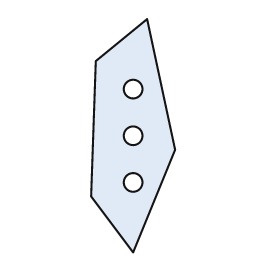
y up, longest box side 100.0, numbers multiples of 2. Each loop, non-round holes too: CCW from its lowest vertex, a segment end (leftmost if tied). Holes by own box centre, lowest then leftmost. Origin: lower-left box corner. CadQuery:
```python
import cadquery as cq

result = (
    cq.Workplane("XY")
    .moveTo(18.0, 0.0)
    .lineTo(36.0, 44.0)
    .lineTo(24.0, 100.0)
    .lineTo(2.0, 82.0)
    .lineTo(0.0, 24.0)
    .close()
    .moveTo(18.0, 30.0)
    .circle(4.0)
    .moveTo(18.0, 50.0)
    .circle(4.0)
    .moveTo(18.0, 70.0)
    .circle(4.0)
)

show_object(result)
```